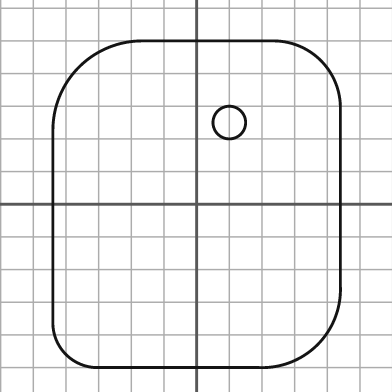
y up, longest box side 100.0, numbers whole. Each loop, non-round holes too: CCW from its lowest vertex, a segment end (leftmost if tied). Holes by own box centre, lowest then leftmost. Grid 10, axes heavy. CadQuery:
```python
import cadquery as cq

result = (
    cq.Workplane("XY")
    .moveTo(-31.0, -50.0)
    .lineTo(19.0, -50.0)
    .threePointArc((37.0, -43.0), (44.0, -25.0))
    .lineTo(44.0, 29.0)
    .threePointArc((38.0, 44.0), (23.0, 50.0))
    .lineTo(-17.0, 50.0)
    .threePointArc((-36.0, 42.0), (-44.0, 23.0))
    .lineTo(-44.0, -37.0)
    .threePointArc((-40.0, -46.0), (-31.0, -50.0))
    .close()
    .moveTo(10.0, 25.0)
    .circle(5.0)
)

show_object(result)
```